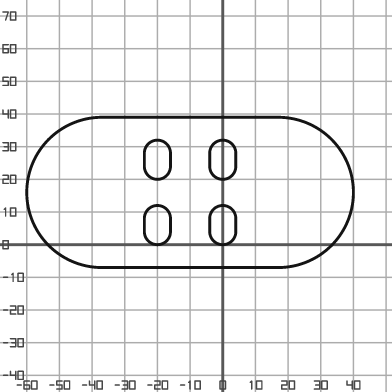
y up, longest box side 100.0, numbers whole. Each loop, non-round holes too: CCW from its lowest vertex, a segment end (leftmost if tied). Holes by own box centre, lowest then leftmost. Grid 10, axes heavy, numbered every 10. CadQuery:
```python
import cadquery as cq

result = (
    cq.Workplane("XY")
    .moveTo(-37.0, -7.0)
    .lineTo(17.0, -7.0)
    .threePointArc((40.0, 16.0), (17.0, 39.0))
    .lineTo(-37.0, 39.0)
    .threePointArc((-60.0, 16.0), (-37.0, -7.0))
    .close()
    .moveTo(-24.0, 4.0)
    .threePointArc((-20.0, 0.0), (-16.0, 4.0))
    .lineTo(-16.0, 8.0)
    .threePointArc((-20.0, 12.0), (-24.0, 8.0))
    .close()
    .moveTo(-4.0, 4.0)
    .threePointArc((0.0, 0.0), (4.0, 4.0))
    .lineTo(4.0, 8.0)
    .threePointArc((0.0, 12.0), (-4.0, 8.0))
    .close()
    .moveTo(-24.0, 24.0)
    .threePointArc((-20.0, 20.0), (-16.0, 24.0))
    .lineTo(-16.0, 28.0)
    .threePointArc((-20.0, 32.0), (-24.0, 28.0))
    .close()
    .moveTo(-4.0, 24.0)
    .threePointArc((0.0, 20.0), (4.0, 24.0))
    .lineTo(4.0, 28.0)
    .threePointArc((0.0, 32.0), (-4.0, 28.0))
    .close()
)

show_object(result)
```